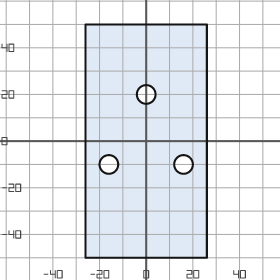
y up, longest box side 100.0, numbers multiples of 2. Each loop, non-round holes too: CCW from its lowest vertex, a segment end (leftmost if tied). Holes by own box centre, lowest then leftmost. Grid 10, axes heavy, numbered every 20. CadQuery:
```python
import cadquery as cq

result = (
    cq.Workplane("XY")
    .moveTo(-26.0, -50.0)
    .lineTo(26.0, -50.0)
    .lineTo(26.0, 50.0)
    .lineTo(-26.0, 50.0)
    .close()
    .moveTo(-16.0, -10.0)
    .circle(4.0)
    .moveTo(16.0, -10.0)
    .circle(4.0)
    .moveTo(0.0, 20.0)
    .circle(4.0)
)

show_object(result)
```